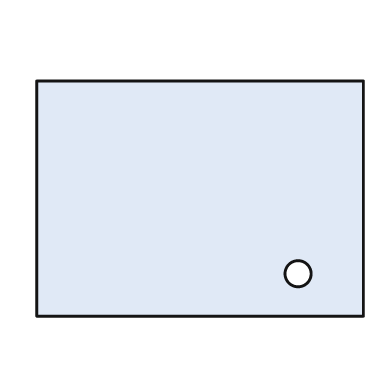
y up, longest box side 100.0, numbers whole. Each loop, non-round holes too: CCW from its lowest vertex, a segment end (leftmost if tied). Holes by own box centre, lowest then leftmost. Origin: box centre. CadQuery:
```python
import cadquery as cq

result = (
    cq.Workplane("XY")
    .moveTo(-50.0, -36.0)
    .lineTo(50.0, -36.0)
    .lineTo(50.0, 36.0)
    .lineTo(-50.0, 36.0)
    .close()
    .moveTo(30.0, -23.0)
    .circle(4.0)
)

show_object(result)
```